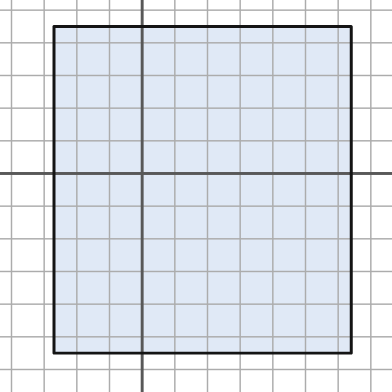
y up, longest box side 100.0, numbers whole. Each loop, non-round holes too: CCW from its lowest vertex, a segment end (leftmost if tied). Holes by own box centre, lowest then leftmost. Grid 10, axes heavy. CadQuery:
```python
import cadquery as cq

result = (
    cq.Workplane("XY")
    .moveTo(-27.0, -55.0)
    .lineTo(64.0, -55.0)
    .lineTo(64.0, 45.0)
    .lineTo(-27.0, 45.0)
    .close()
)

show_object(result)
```